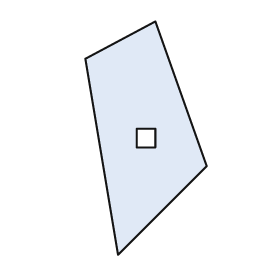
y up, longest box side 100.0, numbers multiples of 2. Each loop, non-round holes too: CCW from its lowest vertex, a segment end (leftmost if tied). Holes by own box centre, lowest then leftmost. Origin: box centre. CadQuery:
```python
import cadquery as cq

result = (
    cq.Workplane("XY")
    .moveTo(-12.0, -50.0)
    .lineTo(26.0, -12.0)
    .lineTo(4.0, 50.0)
    .lineTo(-26.0, 34.0)
    .close()
    .moveTo(-4.0, -4.0)
    .lineTo(4.0, -4.0)
    .lineTo(4.0, 4.0)
    .lineTo(-4.0, 4.0)
    .close()
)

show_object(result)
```